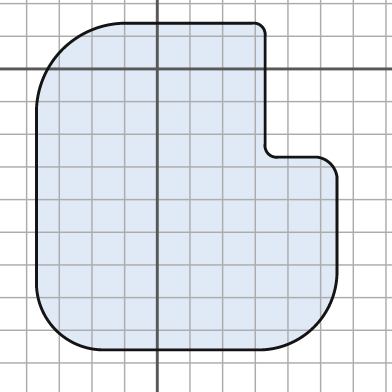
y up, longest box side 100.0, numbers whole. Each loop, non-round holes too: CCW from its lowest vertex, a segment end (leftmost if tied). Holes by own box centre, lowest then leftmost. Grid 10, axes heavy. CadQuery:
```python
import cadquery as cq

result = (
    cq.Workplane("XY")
    .moveTo(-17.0, -86.0)
    .lineTo(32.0, -86.0)
    .threePointArc((48.0, -79.0), (55.0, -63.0))
    .lineTo(55.0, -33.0)
    .threePointArc((53.0, -29.0), (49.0, -27.0))
    .lineTo(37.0, -27.0)
    .threePointArc((34.0, -26.0), (33.0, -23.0))
    .lineTo(33.0, 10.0)
    .threePointArc((32.0, 13.0), (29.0, 14.0))
    .lineTo(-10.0, 14.0)
    .threePointArc((-29.0, 6.0), (-37.0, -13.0))
    .lineTo(-37.0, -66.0)
    .threePointArc((-31.0, -80.0), (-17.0, -86.0))
    .close()
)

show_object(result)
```